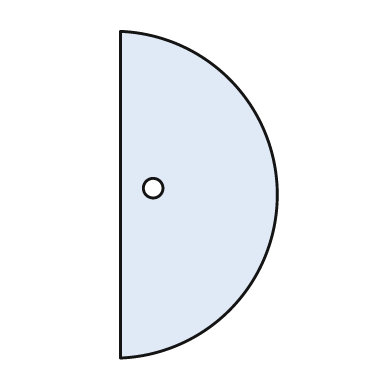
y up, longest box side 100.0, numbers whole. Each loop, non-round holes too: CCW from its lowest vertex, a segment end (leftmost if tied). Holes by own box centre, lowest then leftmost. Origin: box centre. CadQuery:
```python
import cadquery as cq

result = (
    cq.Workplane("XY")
    .moveTo(-24.0, -50.0)
    .threePointArc((24.0, 0.0), (-24.0, 50.0))
    .close()
    .moveTo(-14.0, 2.0)
    .circle(3.0)
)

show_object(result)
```